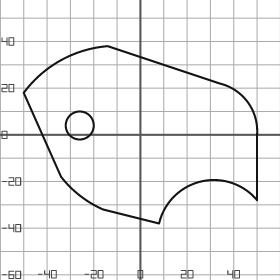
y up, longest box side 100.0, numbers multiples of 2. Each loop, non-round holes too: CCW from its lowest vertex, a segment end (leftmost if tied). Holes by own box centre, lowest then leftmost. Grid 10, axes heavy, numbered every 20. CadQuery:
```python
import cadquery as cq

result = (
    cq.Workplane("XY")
    .moveTo(8.0, -38.0)
    .threePointArc((26.0, -20.0), (50.0, -28.0))
    .lineTo(50.0, 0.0)
    .threePointArc((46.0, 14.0), (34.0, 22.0))
    .lineTo(-14.0, 38.0)
    .threePointArc((-34.0, 32.0), (-50.0, 18.0))
    .lineTo(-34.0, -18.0)
    .threePointArc((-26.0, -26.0), (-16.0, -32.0))
    .close()
    .moveTo(-26.0, 4.0)
    .circle(6.0)
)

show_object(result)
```